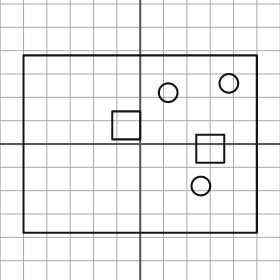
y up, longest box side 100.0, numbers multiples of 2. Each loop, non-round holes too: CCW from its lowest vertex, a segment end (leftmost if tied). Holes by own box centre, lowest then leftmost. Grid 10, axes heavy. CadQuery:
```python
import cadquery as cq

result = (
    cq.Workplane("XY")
    .moveTo(-50.0, -38.0)
    .lineTo(50.0, -38.0)
    .lineTo(50.0, 38.0)
    .lineTo(-50.0, 38.0)
    .close()
    .moveTo(26.0, -18.0)
    .circle(4.0)
    .moveTo(24.0, -8.0)
    .lineTo(36.0, -8.0)
    .lineTo(36.0, 4.0)
    .lineTo(24.0, 4.0)
    .close()
    .moveTo(-12.0, 2.0)
    .lineTo(0.0, 2.0)
    .lineTo(0.0, 14.0)
    .lineTo(-12.0, 14.0)
    .close()
    .moveTo(12.0, 22.0)
    .circle(4.0)
    .moveTo(38.0, 26.0)
    .circle(4.0)
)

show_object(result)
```